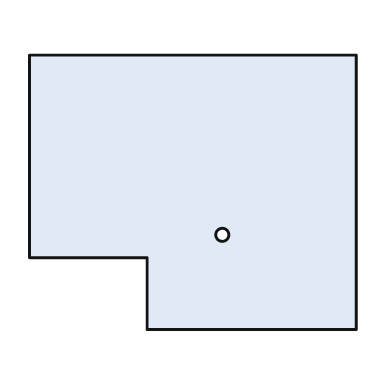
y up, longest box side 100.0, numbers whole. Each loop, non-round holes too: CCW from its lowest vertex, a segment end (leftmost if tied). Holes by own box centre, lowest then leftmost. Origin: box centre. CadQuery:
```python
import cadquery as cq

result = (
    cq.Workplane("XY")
    .moveTo(-14.0, -42.0)
    .lineTo(50.0, -42.0)
    .lineTo(50.0, 42.0)
    .lineTo(-50.0, 42.0)
    .lineTo(-50.0, -20.0)
    .lineTo(-14.0, -20.0)
    .close()
    .moveTo(9.0, -13.0)
    .circle(2.0)
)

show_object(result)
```